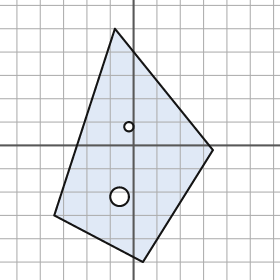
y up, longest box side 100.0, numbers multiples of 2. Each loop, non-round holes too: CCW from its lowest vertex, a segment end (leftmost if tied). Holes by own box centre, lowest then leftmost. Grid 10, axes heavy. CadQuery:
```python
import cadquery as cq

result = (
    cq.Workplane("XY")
    .moveTo(4.0, -50.0)
    .lineTo(34.0, -2.0)
    .lineTo(-8.0, 50.0)
    .lineTo(-34.0, -30.0)
    .close()
    .moveTo(-6.0, -22.0)
    .circle(4.0)
    .moveTo(-2.0, 8.0)
    .circle(2.0)
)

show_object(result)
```